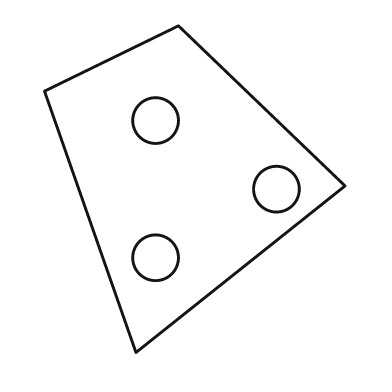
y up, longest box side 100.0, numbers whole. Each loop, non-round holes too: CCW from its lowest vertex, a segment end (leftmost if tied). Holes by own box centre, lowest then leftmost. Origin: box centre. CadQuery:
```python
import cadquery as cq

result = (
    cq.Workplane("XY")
    .moveTo(-18.0, -50.0)
    .lineTo(46.0, 1.0)
    .lineTo(-5.0, 50.0)
    .lineTo(-46.0, 30.0)
    .close()
    .moveTo(-12.0, -21.0)
    .circle(7.0)
    .moveTo(25.0, 0.0)
    .circle(7.0)
    .moveTo(-12.0, 21.0)
    .circle(7.0)
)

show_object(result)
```